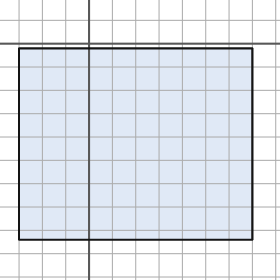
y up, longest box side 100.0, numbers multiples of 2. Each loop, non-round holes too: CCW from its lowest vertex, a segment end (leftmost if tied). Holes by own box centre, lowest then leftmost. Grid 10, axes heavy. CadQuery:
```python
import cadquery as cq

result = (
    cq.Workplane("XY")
    .moveTo(-30.0, -84.0)
    .lineTo(70.0, -84.0)
    .lineTo(70.0, -2.0)
    .lineTo(-30.0, -2.0)
    .close()
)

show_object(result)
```